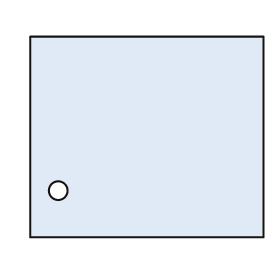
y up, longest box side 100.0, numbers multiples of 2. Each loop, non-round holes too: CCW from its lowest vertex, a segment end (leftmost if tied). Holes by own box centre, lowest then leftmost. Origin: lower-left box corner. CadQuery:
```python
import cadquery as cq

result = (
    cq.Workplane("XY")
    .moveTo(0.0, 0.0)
    .lineTo(100.0, 0.0)
    .lineTo(100.0, 86.0)
    .lineTo(0.0, 86.0)
    .close()
    .moveTo(12.0, 20.0)
    .circle(4.0)
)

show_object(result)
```